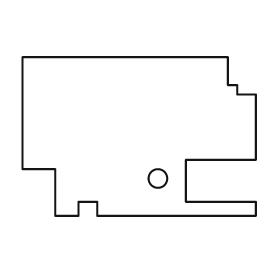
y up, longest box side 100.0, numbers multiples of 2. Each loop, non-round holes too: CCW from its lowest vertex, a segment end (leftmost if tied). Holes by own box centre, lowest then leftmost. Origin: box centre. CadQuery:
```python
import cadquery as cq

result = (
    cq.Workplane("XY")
    .moveTo(-36.0, -34.0)
    .lineTo(-26.0, -34.0)
    .lineTo(-26.0, -28.0)
    .lineTo(-18.0, -28.0)
    .lineTo(-18.0, -34.0)
    .lineTo(50.0, -34.0)
    .lineTo(50.0, -28.0)
    .lineTo(20.0, -28.0)
    .lineTo(20.0, -10.0)
    .lineTo(50.0, -10.0)
    .lineTo(50.0, 18.0)
    .lineTo(42.0, 18.0)
    .lineTo(42.0, 22.0)
    .lineTo(38.0, 22.0)
    .lineTo(38.0, 34.0)
    .lineTo(-50.0, 34.0)
    .lineTo(-50.0, -14.0)
    .lineTo(-36.0, -14.0)
    .close()
    .moveTo(8.0, -18.0)
    .circle(4.0)
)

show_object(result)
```